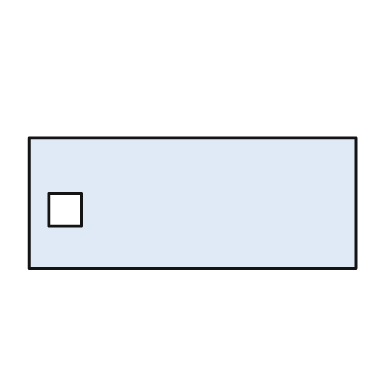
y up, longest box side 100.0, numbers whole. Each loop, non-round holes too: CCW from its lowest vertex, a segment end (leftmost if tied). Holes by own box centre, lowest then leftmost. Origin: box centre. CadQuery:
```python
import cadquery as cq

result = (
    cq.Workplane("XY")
    .moveTo(-50.0, -20.0)
    .lineTo(50.0, -20.0)
    .lineTo(50.0, 20.0)
    .lineTo(-50.0, 20.0)
    .close()
    .moveTo(-44.0, -7.0)
    .lineTo(-34.0, -7.0)
    .lineTo(-34.0, 3.0)
    .lineTo(-44.0, 3.0)
    .close()
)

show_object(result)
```